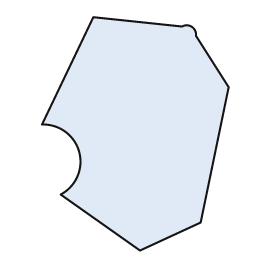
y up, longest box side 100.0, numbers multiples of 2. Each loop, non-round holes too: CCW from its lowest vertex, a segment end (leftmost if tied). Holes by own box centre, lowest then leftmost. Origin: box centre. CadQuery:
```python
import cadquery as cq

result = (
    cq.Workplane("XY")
    .moveTo(2.0, -50.0)
    .lineTo(28.0, -38.0)
    .lineTo(40.0, 20.0)
    .lineTo(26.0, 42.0)
    .threePointArc((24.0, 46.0), (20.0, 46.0))
    .lineTo(-18.0, 50.0)
    .lineTo(-40.0, 4.0)
    .threePointArc((-24.0, -8.0), (-32.0, -26.0))
    .close()
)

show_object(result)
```